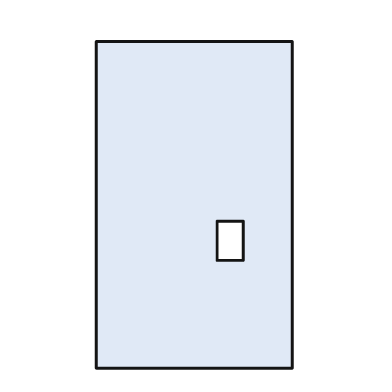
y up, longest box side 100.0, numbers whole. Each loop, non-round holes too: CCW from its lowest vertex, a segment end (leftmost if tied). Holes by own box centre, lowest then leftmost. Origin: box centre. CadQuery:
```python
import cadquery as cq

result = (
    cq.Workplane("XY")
    .moveTo(-30.0, -50.0)
    .lineTo(30.0, -50.0)
    .lineTo(30.0, 50.0)
    .lineTo(-30.0, 50.0)
    .close()
    .moveTo(7.0, -17.0)
    .lineTo(15.0, -17.0)
    .lineTo(15.0, -5.0)
    .lineTo(7.0, -5.0)
    .close()
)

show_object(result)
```